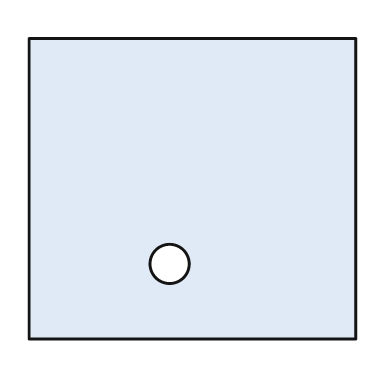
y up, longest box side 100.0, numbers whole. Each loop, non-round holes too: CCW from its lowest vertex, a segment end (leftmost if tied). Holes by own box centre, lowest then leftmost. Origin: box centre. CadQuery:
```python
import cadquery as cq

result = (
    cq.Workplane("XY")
    .moveTo(-50.0, -46.0)
    .lineTo(50.0, -46.0)
    .lineTo(50.0, 46.0)
    .lineTo(-50.0, 46.0)
    .close()
    .moveTo(-7.0, -23.0)
    .circle(6.0)
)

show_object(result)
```